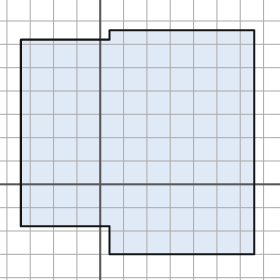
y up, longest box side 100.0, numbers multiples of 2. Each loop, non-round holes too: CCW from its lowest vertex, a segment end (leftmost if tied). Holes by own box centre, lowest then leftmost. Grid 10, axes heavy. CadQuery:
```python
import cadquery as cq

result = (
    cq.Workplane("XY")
    .moveTo(4.0, -30.0)
    .lineTo(66.0, -30.0)
    .lineTo(66.0, 66.0)
    .lineTo(4.0, 66.0)
    .lineTo(4.0, 62.0)
    .lineTo(-34.0, 62.0)
    .lineTo(-34.0, -18.0)
    .lineTo(4.0, -18.0)
    .close()
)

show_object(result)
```